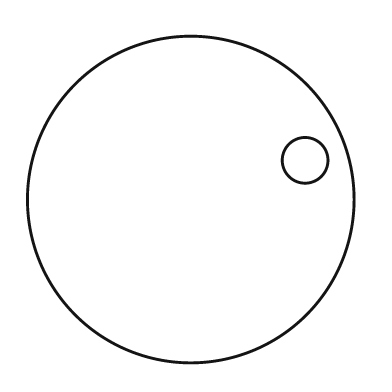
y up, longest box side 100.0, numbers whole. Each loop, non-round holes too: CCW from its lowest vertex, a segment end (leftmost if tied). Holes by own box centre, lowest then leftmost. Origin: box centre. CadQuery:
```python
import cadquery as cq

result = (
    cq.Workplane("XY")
    .moveTo(0.0, 0.0)
    .circle(50.0)
    .moveTo(35.0, 12.0)
    .circle(7.0)
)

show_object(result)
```